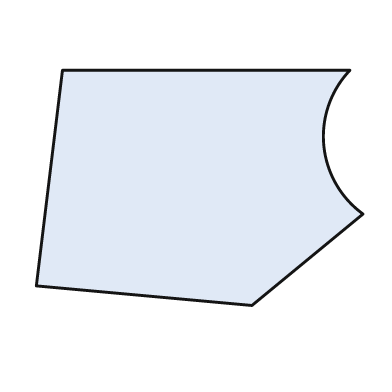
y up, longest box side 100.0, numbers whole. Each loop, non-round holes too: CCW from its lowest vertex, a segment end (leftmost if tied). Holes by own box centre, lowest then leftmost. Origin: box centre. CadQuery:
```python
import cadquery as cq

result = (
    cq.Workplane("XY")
    .moveTo(16.0, -36.0)
    .lineTo(50.0, -8.0)
    .threePointArc((38.0, 13.0), (46.0, 36.0))
    .lineTo(-42.0, 36.0)
    .lineTo(-50.0, -30.0)
    .close()
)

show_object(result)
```